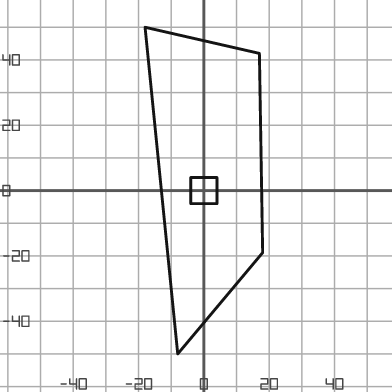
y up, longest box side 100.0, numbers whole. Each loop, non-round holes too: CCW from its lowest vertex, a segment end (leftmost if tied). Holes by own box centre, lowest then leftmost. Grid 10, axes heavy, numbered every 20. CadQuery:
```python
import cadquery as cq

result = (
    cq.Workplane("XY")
    .moveTo(-8.0, -50.0)
    .lineTo(18.0, -19.0)
    .lineTo(17.0, 42.0)
    .lineTo(-18.0, 50.0)
    .close()
    .moveTo(-4.0, -4.0)
    .lineTo(4.0, -4.0)
    .lineTo(4.0, 4.0)
    .lineTo(-4.0, 4.0)
    .close()
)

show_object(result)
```